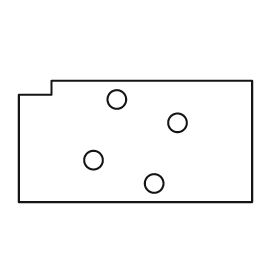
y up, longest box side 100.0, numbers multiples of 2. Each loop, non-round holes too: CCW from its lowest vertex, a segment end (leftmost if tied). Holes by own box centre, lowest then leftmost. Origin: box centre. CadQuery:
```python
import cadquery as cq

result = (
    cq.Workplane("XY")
    .moveTo(-50.0, -26.0)
    .lineTo(50.0, -26.0)
    .lineTo(50.0, 26.0)
    .lineTo(-36.0, 26.0)
    .lineTo(-36.0, 20.0)
    .lineTo(-50.0, 20.0)
    .close()
    .moveTo(8.0, -18.0)
    .circle(4.0)
    .moveTo(-18.0, -8.0)
    .circle(4.0)
    .moveTo(18.0, 8.0)
    .circle(4.0)
    .moveTo(-8.0, 18.0)
    .circle(4.0)
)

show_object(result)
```